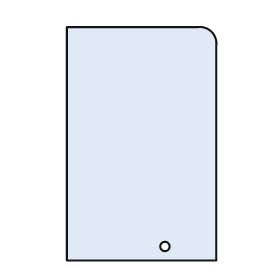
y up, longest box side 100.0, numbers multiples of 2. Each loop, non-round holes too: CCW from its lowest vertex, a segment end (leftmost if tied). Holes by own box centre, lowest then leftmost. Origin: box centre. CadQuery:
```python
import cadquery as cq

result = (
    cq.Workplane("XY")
    .moveTo(-32.0, -50.0)
    .lineTo(32.0, -50.0)
    .lineTo(32.0, 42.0)
    .threePointArc((30.0, 48.0), (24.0, 50.0))
    .lineTo(-32.0, 50.0)
    .close()
    .moveTo(10.0, -44.0)
    .circle(2.0)
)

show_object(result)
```